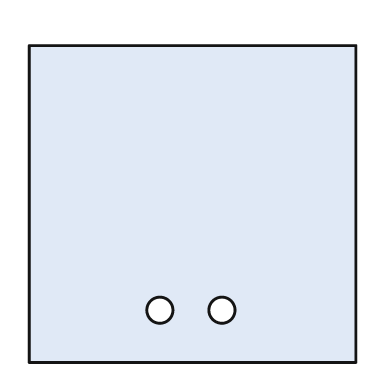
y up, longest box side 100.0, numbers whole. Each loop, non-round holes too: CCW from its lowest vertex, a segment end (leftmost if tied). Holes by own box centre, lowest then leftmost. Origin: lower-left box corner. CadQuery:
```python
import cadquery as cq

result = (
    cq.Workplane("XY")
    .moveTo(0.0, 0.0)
    .lineTo(100.0, 0.0)
    .lineTo(100.0, 97.0)
    .lineTo(0.0, 97.0)
    .close()
    .moveTo(40.0, 16.0)
    .circle(4.0)
    .moveTo(59.0, 16.0)
    .circle(4.0)
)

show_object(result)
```